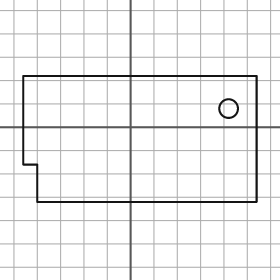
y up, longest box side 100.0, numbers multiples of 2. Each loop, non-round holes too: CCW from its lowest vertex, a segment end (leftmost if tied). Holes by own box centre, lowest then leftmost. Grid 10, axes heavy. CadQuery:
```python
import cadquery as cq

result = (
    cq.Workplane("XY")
    .moveTo(-40.0, -32.0)
    .lineTo(54.0, -32.0)
    .lineTo(54.0, 22.0)
    .lineTo(-46.0, 22.0)
    .lineTo(-46.0, -16.0)
    .lineTo(-40.0, -16.0)
    .close()
    .moveTo(42.0, 8.0)
    .circle(4.0)
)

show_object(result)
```